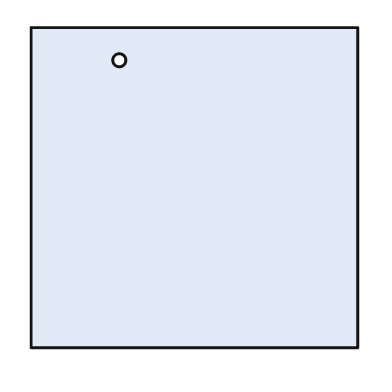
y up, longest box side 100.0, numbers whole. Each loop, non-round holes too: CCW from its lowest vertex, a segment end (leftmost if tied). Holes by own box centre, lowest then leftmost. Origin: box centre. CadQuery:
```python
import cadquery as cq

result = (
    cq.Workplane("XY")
    .moveTo(-50.0, -49.0)
    .lineTo(50.0, -49.0)
    .lineTo(50.0, 49.0)
    .lineTo(-50.0, 49.0)
    .close()
    .moveTo(-23.0, 39.0)
    .circle(2.0)
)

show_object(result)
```